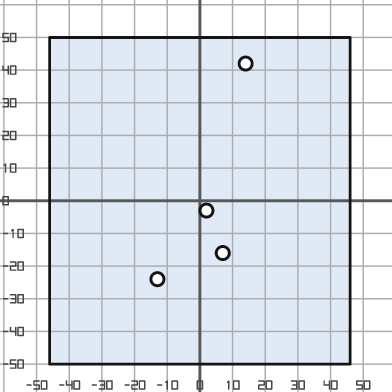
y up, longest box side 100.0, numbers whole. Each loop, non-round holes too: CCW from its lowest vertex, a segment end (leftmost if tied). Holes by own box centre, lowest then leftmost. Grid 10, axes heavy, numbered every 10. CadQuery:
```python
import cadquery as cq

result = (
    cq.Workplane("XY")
    .moveTo(-46.0, -50.0)
    .lineTo(46.0, -50.0)
    .lineTo(46.0, 50.0)
    .lineTo(-46.0, 50.0)
    .close()
    .moveTo(-13.0, -24.0)
    .circle(2.0)
    .moveTo(7.0, -16.0)
    .circle(2.0)
    .moveTo(2.0, -3.0)
    .circle(2.0)
    .moveTo(14.0, 42.0)
    .circle(2.0)
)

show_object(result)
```